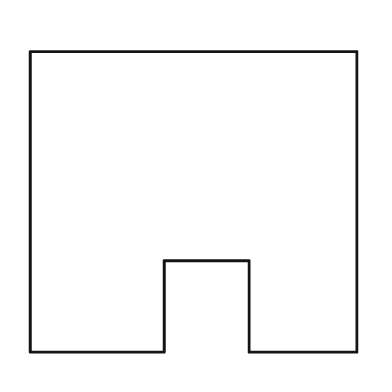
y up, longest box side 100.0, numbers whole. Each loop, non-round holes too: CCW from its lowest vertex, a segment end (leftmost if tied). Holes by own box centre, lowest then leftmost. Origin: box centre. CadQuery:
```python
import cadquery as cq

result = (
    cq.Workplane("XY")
    .moveTo(-50.0, -46.0)
    .lineTo(-9.0, -46.0)
    .lineTo(-9.0, -18.0)
    .lineTo(17.0, -18.0)
    .lineTo(17.0, -46.0)
    .lineTo(50.0, -46.0)
    .lineTo(50.0, 46.0)
    .lineTo(-50.0, 46.0)
    .close()
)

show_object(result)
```